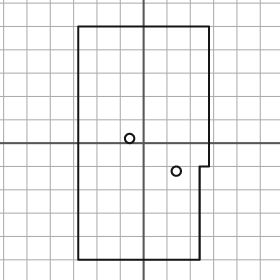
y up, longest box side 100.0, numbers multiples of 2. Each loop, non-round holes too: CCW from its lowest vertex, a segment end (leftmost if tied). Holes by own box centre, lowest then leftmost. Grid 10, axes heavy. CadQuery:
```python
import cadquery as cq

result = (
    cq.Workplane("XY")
    .moveTo(-28.0, -50.0)
    .lineTo(24.0, -50.0)
    .lineTo(24.0, -10.0)
    .lineTo(28.0, -10.0)
    .lineTo(28.0, 50.0)
    .lineTo(-28.0, 50.0)
    .close()
    .moveTo(14.0, -12.0)
    .circle(2.0)
    .moveTo(-6.0, 2.0)
    .circle(2.0)
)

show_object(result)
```